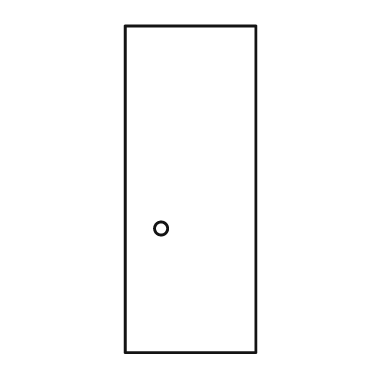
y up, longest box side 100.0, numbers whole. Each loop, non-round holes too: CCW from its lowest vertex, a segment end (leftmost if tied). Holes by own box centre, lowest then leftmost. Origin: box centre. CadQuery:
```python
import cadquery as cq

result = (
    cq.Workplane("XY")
    .moveTo(-20.0, -50.0)
    .lineTo(20.0, -50.0)
    .lineTo(20.0, 50.0)
    .lineTo(-20.0, 50.0)
    .close()
    .moveTo(-9.0, -12.0)
    .circle(2.0)
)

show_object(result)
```